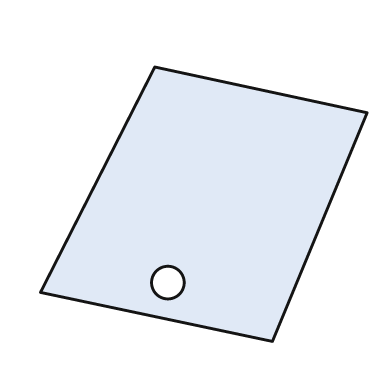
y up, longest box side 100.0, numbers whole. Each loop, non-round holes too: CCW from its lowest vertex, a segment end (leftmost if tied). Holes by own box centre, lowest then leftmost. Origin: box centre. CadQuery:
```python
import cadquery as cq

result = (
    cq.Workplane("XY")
    .moveTo(21.0, -42.0)
    .lineTo(50.0, 28.0)
    .lineTo(-15.0, 42.0)
    .lineTo(-50.0, -27.0)
    .close()
    .moveTo(-11.0, -24.0)
    .circle(5.0)
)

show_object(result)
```